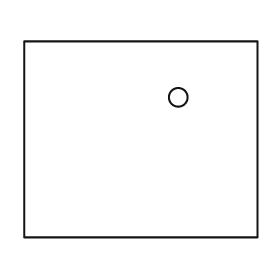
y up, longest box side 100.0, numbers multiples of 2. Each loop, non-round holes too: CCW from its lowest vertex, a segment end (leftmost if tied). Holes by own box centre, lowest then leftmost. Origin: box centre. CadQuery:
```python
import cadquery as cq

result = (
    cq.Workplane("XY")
    .moveTo(-50.0, -42.0)
    .lineTo(50.0, -42.0)
    .lineTo(50.0, 42.0)
    .lineTo(-50.0, 42.0)
    .close()
    .moveTo(16.0, 18.0)
    .circle(4.0)
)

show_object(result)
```